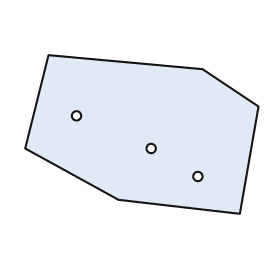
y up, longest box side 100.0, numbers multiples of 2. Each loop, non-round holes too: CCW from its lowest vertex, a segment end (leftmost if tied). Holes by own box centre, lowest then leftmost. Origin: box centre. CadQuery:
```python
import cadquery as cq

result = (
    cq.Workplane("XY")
    .moveTo(42.0, -34.0)
    .lineTo(50.0, 12.0)
    .lineTo(26.0, 28.0)
    .lineTo(-40.0, 34.0)
    .lineTo(-50.0, -6.0)
    .lineTo(-10.0, -28.0)
    .close()
    .moveTo(24.0, -18.0)
    .circle(2.0)
    .moveTo(4.0, -6.0)
    .circle(2.0)
    .moveTo(-28.0, 8.0)
    .circle(2.0)
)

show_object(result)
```